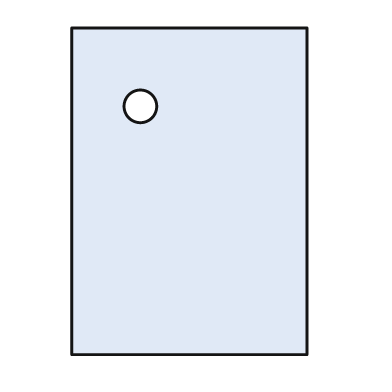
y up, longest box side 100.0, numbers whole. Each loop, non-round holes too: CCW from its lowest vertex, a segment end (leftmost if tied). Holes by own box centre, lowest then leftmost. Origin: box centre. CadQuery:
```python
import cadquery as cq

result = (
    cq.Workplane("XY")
    .moveTo(-36.0, -50.0)
    .lineTo(36.0, -50.0)
    .lineTo(36.0, 50.0)
    .lineTo(-36.0, 50.0)
    .close()
    .moveTo(-15.0, 26.0)
    .circle(5.0)
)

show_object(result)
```